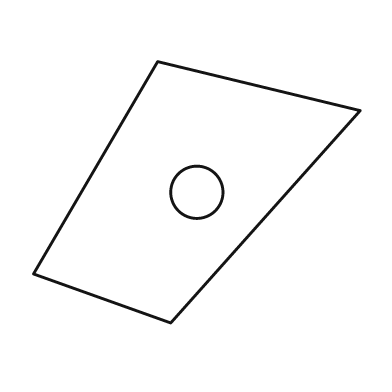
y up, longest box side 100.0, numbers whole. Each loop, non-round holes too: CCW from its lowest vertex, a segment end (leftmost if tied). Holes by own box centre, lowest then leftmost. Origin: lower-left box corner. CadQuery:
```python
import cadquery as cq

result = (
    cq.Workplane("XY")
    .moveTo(42.0, 0.0)
    .lineTo(100.0, 65.0)
    .lineTo(38.0, 80.0)
    .lineTo(0.0, 15.0)
    .close()
    .moveTo(50.0, 40.0)
    .circle(8.0)
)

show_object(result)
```